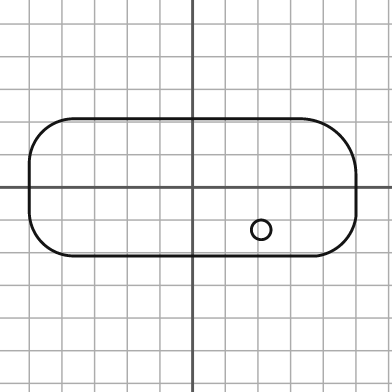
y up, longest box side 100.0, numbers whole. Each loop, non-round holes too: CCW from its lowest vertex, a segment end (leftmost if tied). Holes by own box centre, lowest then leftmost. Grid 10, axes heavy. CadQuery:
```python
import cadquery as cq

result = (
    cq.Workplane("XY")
    .moveTo(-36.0, -21.0)
    .lineTo(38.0, -21.0)
    .threePointArc((46.0, -17.0), (50.0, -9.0))
    .lineTo(50.0, 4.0)
    .threePointArc((45.0, 16.0), (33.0, 21.0))
    .lineTo(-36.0, 21.0)
    .threePointArc((-46.0, 17.0), (-50.0, 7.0))
    .lineTo(-50.0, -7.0)
    .threePointArc((-46.0, -17.0), (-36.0, -21.0))
    .close()
    .moveTo(21.0, -13.0)
    .circle(3.0)
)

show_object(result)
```